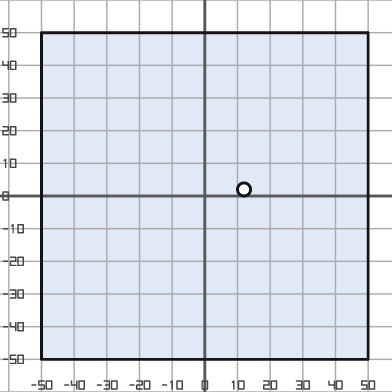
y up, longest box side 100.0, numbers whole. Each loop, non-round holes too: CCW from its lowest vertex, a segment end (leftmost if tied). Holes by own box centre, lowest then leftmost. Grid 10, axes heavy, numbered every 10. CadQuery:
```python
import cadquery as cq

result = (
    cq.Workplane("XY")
    .moveTo(-50.0, -50.0)
    .lineTo(50.0, -50.0)
    .lineTo(50.0, 50.0)
    .lineTo(-50.0, 50.0)
    .close()
    .moveTo(12.0, 2.0)
    .circle(2.0)
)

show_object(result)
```